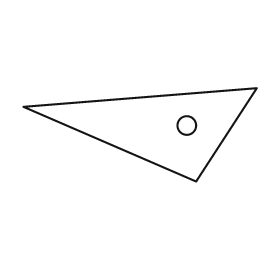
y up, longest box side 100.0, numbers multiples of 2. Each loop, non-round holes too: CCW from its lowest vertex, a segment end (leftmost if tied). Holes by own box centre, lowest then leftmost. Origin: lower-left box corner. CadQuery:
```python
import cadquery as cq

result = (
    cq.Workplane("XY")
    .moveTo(74.0, 0.0)
    .lineTo(100.0, 40.0)
    .lineTo(0.0, 32.0)
    .close()
    .moveTo(70.0, 24.0)
    .circle(4.0)
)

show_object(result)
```